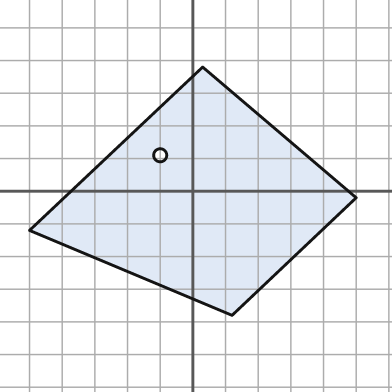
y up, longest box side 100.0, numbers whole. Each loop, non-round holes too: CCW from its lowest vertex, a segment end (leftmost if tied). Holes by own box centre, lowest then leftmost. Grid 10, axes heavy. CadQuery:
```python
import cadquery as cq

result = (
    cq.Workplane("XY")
    .moveTo(12.0, -38.0)
    .lineTo(50.0, -2.0)
    .lineTo(3.0, 38.0)
    .lineTo(-50.0, -12.0)
    .close()
    .moveTo(-10.0, 11.0)
    .circle(2.0)
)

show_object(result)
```